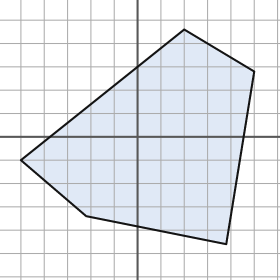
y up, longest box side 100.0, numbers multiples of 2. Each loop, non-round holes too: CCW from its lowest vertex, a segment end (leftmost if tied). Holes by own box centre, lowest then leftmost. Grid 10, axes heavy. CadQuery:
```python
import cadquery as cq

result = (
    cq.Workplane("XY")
    .moveTo(38.0, -46.0)
    .lineTo(50.0, 28.0)
    .lineTo(20.0, 46.0)
    .lineTo(-50.0, -10.0)
    .lineTo(-22.0, -34.0)
    .close()
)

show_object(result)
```